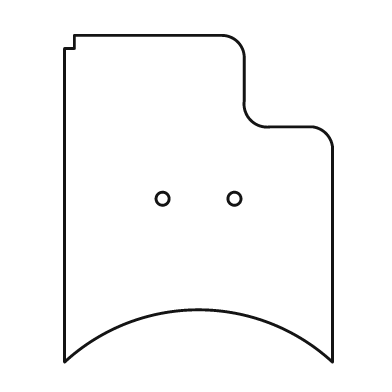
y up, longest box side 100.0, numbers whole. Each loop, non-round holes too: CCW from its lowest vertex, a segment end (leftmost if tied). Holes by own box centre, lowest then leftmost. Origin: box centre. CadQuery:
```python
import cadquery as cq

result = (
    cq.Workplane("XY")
    .moveTo(-41.0, -50.0)
    .threePointArc((0.0, -34.0), (41.0, -50.0))
    .lineTo(41.0, 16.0)
    .threePointArc((39.0, 20.0), (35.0, 22.0))
    .lineTo(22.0, 22.0)
    .threePointArc((16.0, 24.0), (14.0, 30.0))
    .lineTo(14.0, 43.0)
    .threePointArc((12.0, 48.0), (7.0, 50.0))
    .lineTo(-38.0, 50.0)
    .lineTo(-38.0, 46.0)
    .lineTo(-41.0, 46.0)
    .close()
    .moveTo(-11.0, 0.0)
    .circle(2.0)
    .moveTo(11.0, 0.0)
    .circle(2.0)
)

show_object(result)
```